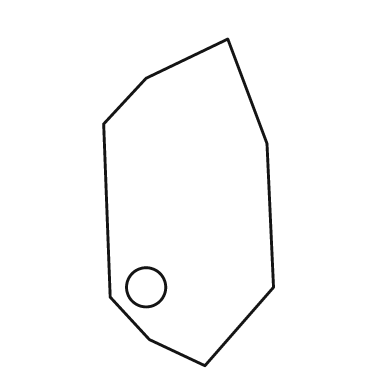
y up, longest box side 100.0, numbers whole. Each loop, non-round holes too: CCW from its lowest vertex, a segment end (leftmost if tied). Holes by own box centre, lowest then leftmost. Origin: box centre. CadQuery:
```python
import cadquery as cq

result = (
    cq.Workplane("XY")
    .moveTo(5.0, -50.0)
    .lineTo(26.0, -26.0)
    .lineTo(24.0, 18.0)
    .lineTo(12.0, 50.0)
    .lineTo(-13.0, 38.0)
    .lineTo(-26.0, 24.0)
    .lineTo(-24.0, -29.0)
    .lineTo(-12.0, -42.0)
    .close()
    .moveTo(-13.0, -26.0)
    .circle(6.0)
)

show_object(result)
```